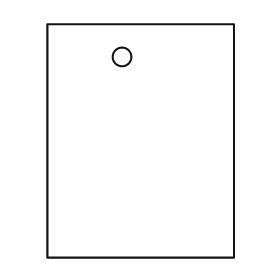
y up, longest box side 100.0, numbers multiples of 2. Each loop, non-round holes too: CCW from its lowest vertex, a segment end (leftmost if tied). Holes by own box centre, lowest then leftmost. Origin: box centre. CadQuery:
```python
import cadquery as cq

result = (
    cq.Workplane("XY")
    .moveTo(-40.0, -50.0)
    .lineTo(40.0, -50.0)
    .lineTo(40.0, 50.0)
    .lineTo(-40.0, 50.0)
    .close()
    .moveTo(-8.0, 36.0)
    .circle(4.0)
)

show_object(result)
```